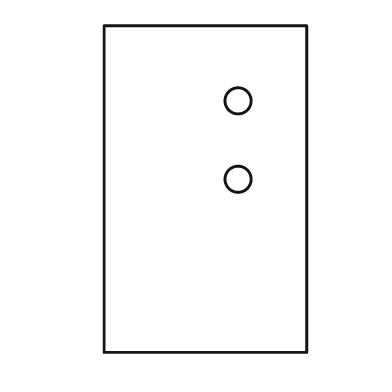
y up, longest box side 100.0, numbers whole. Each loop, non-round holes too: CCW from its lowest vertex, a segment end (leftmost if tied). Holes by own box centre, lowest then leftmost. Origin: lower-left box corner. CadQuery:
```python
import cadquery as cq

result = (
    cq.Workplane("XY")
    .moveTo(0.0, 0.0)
    .lineTo(62.0, 0.0)
    .lineTo(62.0, 100.0)
    .lineTo(0.0, 100.0)
    .close()
    .moveTo(41.0, 53.0)
    .circle(4.0)
    .moveTo(41.0, 77.0)
    .circle(4.0)
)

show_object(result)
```